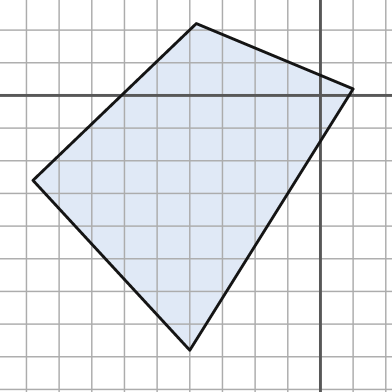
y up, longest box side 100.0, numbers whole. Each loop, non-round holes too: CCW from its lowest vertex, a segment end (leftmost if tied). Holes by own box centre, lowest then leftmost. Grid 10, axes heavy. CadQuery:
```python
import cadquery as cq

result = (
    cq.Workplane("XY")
    .moveTo(-40.0, -78.0)
    .lineTo(10.0, 2.0)
    .lineTo(-38.0, 22.0)
    .lineTo(-88.0, -26.0)
    .close()
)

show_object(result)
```